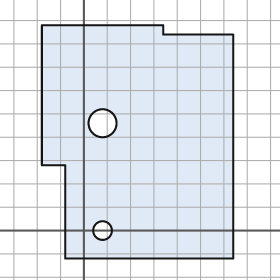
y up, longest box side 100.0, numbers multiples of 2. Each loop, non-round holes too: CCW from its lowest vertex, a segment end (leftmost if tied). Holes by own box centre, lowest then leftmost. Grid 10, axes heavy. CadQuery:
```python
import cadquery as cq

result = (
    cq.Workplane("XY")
    .moveTo(-8.0, -12.0)
    .lineTo(64.0, -12.0)
    .lineTo(64.0, 84.0)
    .lineTo(34.0, 84.0)
    .lineTo(34.0, 88.0)
    .lineTo(-18.0, 88.0)
    .lineTo(-18.0, 28.0)
    .lineTo(-8.0, 28.0)
    .close()
    .moveTo(8.0, 0.0)
    .circle(4.0)
    .moveTo(8.0, 46.0)
    .circle(6.0)
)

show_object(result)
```